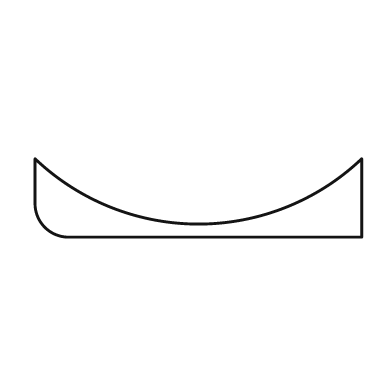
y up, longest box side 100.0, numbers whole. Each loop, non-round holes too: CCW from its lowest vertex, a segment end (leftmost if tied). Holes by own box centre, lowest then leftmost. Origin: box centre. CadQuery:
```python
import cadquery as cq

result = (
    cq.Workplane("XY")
    .moveTo(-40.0, -12.0)
    .lineTo(50.0, -12.0)
    .lineTo(50.0, 12.0)
    .threePointArc((0.0, -8.0), (-50.0, 12.0))
    .lineTo(-50.0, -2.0)
    .threePointArc((-47.0, -9.0), (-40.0, -12.0))
    .close()
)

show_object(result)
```